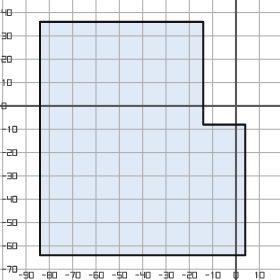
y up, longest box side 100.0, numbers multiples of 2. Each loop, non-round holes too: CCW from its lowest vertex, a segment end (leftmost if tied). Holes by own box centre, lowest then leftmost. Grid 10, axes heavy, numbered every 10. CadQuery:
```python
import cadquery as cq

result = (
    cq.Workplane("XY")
    .moveTo(-84.0, -64.0)
    .lineTo(4.0, -64.0)
    .lineTo(4.0, -8.0)
    .lineTo(-14.0, -8.0)
    .lineTo(-14.0, 36.0)
    .lineTo(-84.0, 36.0)
    .close()
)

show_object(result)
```